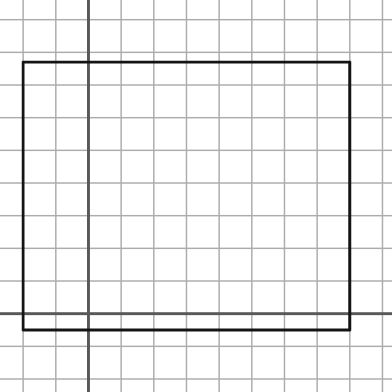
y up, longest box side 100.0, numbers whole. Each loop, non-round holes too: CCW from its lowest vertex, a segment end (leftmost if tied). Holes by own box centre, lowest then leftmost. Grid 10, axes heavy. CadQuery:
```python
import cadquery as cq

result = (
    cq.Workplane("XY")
    .moveTo(-20.0, -5.0)
    .lineTo(80.0, -5.0)
    .lineTo(80.0, 77.0)
    .lineTo(-20.0, 77.0)
    .close()
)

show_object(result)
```